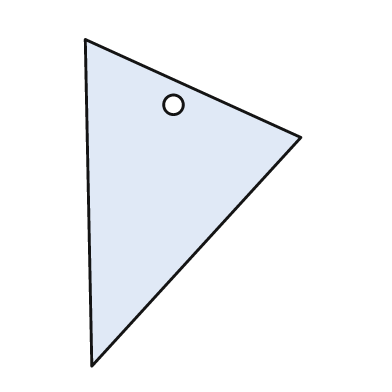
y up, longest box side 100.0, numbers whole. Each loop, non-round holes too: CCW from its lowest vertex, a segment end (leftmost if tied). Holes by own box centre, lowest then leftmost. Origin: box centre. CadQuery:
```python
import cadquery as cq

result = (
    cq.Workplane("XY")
    .moveTo(-31.0, -50.0)
    .lineTo(33.0, 20.0)
    .lineTo(-33.0, 50.0)
    .close()
    .moveTo(-6.0, 30.0)
    .circle(3.0)
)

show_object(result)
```